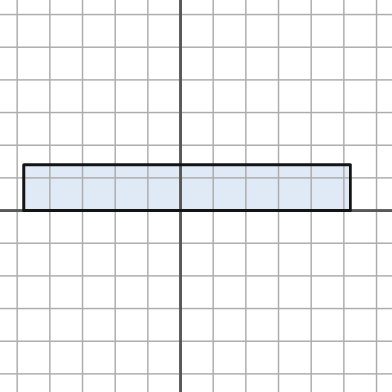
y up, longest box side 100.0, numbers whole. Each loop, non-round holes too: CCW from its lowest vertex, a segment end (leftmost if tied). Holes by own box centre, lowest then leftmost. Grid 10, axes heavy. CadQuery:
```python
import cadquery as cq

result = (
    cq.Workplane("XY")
    .moveTo(-48.0, 0.0)
    .lineTo(52.0, 0.0)
    .lineTo(52.0, 14.0)
    .lineTo(-48.0, 14.0)
    .close()
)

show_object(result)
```